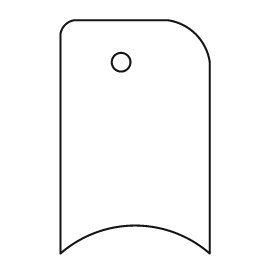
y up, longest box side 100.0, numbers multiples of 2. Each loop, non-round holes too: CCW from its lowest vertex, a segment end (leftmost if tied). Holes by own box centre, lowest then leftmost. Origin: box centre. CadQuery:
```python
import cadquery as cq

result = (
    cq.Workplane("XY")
    .moveTo(-32.0, -50.0)
    .threePointArc((0.0, -38.0), (32.0, -50.0))
    .lineTo(32.0, 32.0)
    .threePointArc((26.0, 44.0), (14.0, 50.0))
    .lineTo(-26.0, 50.0)
    .threePointArc((-30.0, 48.0), (-32.0, 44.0))
    .close()
    .moveTo(-6.0, 32.0)
    .circle(4.0)
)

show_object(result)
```